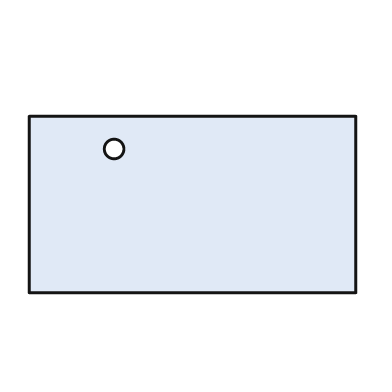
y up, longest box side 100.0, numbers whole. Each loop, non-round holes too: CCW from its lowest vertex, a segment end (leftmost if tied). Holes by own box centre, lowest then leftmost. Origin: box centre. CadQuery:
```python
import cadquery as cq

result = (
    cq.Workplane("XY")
    .moveTo(-50.0, -27.0)
    .lineTo(50.0, -27.0)
    .lineTo(50.0, 27.0)
    .lineTo(-50.0, 27.0)
    .close()
    .moveTo(-24.0, 17.0)
    .circle(3.0)
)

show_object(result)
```